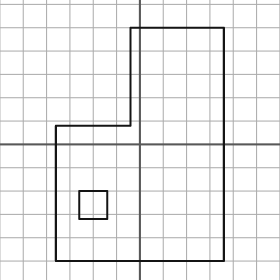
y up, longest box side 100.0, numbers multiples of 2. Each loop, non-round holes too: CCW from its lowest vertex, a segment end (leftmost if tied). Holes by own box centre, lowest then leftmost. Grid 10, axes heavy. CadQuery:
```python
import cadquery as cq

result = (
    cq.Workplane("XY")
    .moveTo(-36.0, -50.0)
    .lineTo(36.0, -50.0)
    .lineTo(36.0, 50.0)
    .lineTo(-4.0, 50.0)
    .lineTo(-4.0, 8.0)
    .lineTo(-36.0, 8.0)
    .close()
    .moveTo(-26.0, -32.0)
    .lineTo(-14.0, -32.0)
    .lineTo(-14.0, -20.0)
    .lineTo(-26.0, -20.0)
    .close()
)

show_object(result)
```